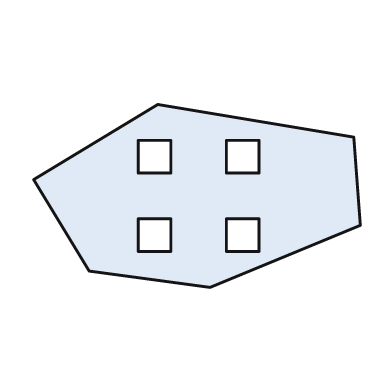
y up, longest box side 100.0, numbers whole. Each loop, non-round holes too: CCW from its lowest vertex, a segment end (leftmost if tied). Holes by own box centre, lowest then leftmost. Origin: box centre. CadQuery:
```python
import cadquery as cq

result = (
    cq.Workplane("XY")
    .moveTo(4.0, -28.0)
    .lineTo(50.0, -9.0)
    .lineTo(48.0, 18.0)
    .lineTo(-12.0, 28.0)
    .lineTo(-50.0, 5.0)
    .lineTo(-33.0, -23.0)
    .close()
    .moveTo(-18.0, -17.0)
    .lineTo(-8.0, -17.0)
    .lineTo(-8.0, -7.0)
    .lineTo(-18.0, -7.0)
    .close()
    .moveTo(9.0, -17.0)
    .lineTo(19.0, -17.0)
    .lineTo(19.0, -7.0)
    .lineTo(9.0, -7.0)
    .close()
    .moveTo(-18.0, 7.0)
    .lineTo(-8.0, 7.0)
    .lineTo(-8.0, 17.0)
    .lineTo(-18.0, 17.0)
    .close()
    .moveTo(9.0, 7.0)
    .lineTo(19.0, 7.0)
    .lineTo(19.0, 17.0)
    .lineTo(9.0, 17.0)
    .close()
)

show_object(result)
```